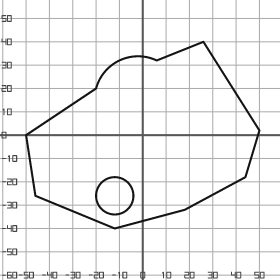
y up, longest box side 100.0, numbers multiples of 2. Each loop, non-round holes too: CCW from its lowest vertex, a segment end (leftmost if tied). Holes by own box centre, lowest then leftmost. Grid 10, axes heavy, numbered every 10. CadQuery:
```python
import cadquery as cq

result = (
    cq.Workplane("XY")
    .moveTo(-12.0, -40.0)
    .lineTo(18.0, -32.0)
    .lineTo(44.0, -18.0)
    .lineTo(50.0, 2.0)
    .lineTo(26.0, 40.0)
    .lineTo(6.0, 32.0)
    .threePointArc((-10.0, 32.0), (-20.0, 20.0))
    .lineTo(-50.0, 0.0)
    .lineTo(-46.0, -26.0)
    .close()
    .moveTo(-12.0, -26.0)
    .circle(8.0)
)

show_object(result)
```